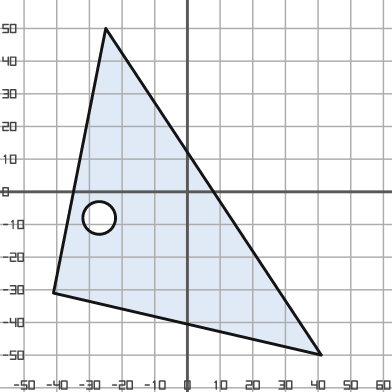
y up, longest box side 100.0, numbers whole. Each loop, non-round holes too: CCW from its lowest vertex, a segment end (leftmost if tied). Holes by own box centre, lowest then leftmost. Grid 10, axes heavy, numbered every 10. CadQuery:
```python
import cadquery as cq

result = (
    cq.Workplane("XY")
    .moveTo(41.0, -50.0)
    .lineTo(-25.0, 50.0)
    .lineTo(-41.0, -31.0)
    .close()
    .moveTo(-27.0, -8.0)
    .circle(5.0)
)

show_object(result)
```